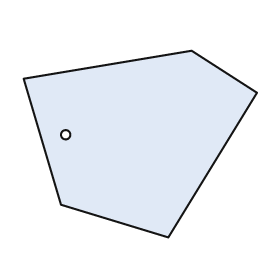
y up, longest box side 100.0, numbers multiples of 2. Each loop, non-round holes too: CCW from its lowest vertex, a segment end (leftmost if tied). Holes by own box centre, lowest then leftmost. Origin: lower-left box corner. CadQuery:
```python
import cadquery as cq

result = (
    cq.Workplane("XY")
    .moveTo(62.0, 0.0)
    .lineTo(100.0, 62.0)
    .lineTo(72.0, 80.0)
    .lineTo(0.0, 68.0)
    .lineTo(16.0, 14.0)
    .close()
    .moveTo(18.0, 44.0)
    .circle(2.0)
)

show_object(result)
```